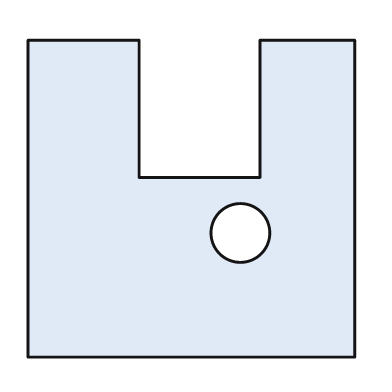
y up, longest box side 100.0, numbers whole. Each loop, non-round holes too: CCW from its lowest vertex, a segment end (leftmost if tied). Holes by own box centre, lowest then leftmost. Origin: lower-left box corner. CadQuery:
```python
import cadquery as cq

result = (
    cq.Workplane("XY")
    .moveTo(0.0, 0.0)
    .lineTo(100.0, 0.0)
    .lineTo(100.0, 97.0)
    .lineTo(71.0, 97.0)
    .lineTo(71.0, 55.0)
    .lineTo(34.0, 55.0)
    .lineTo(34.0, 97.0)
    .lineTo(0.0, 97.0)
    .close()
    .moveTo(65.0, 38.0)
    .circle(9.0)
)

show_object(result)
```